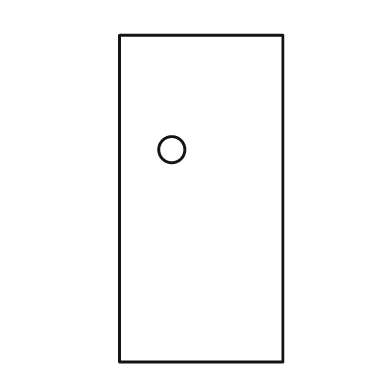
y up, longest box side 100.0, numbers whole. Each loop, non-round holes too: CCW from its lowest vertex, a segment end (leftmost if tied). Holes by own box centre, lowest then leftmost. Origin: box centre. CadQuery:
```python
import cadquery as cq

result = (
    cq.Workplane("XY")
    .moveTo(-25.0, -50.0)
    .lineTo(25.0, -50.0)
    .lineTo(25.0, 50.0)
    .lineTo(-25.0, 50.0)
    .close()
    .moveTo(-9.0, 15.0)
    .circle(4.0)
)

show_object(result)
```